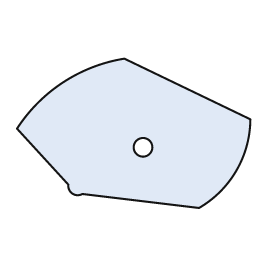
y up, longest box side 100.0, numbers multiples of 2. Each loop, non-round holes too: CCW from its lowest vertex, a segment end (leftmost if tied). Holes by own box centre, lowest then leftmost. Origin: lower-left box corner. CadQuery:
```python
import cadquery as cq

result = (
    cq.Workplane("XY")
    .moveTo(78.0, 0.0)
    .threePointArc((94.0, 16.0), (100.0, 38.0))
    .lineTo(46.0, 64.0)
    .threePointArc((20.0, 54.0), (0.0, 34.0))
    .lineTo(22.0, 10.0)
    .threePointArc((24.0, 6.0), (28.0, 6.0))
    .close()
    .moveTo(54.0, 26.0)
    .circle(4.0)
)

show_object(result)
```